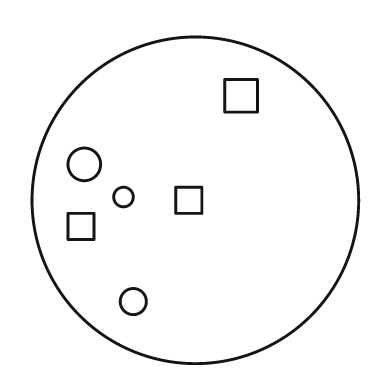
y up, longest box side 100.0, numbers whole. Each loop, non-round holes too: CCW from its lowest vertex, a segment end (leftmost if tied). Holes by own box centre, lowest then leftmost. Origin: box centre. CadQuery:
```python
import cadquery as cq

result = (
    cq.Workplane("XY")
    .moveTo(0.0, 0.0)
    .circle(50.0)
    .moveTo(-19.0, -31.0)
    .circle(4.0)
    .moveTo(-39.0, -12.0)
    .lineTo(-31.0, -12.0)
    .lineTo(-31.0, -4.0)
    .lineTo(-39.0, -4.0)
    .close()
    .moveTo(-6.0, -4.0)
    .lineTo(2.0, -4.0)
    .lineTo(2.0, 4.0)
    .lineTo(-6.0, 4.0)
    .close()
    .moveTo(-22.0, 1.0)
    .circle(3.0)
    .moveTo(-34.0, 11.0)
    .circle(5.0)
    .moveTo(9.0, 27.0)
    .lineTo(19.0, 27.0)
    .lineTo(19.0, 37.0)
    .lineTo(9.0, 37.0)
    .close()
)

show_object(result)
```